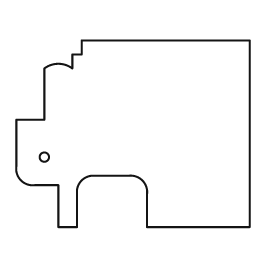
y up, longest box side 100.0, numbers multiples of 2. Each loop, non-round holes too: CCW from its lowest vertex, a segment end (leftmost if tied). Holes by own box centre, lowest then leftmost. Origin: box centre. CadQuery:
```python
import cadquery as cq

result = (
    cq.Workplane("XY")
    .moveTo(-32.0, -40.0)
    .lineTo(-24.0, -40.0)
    .lineTo(-24.0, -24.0)
    .threePointArc((-22.0, -20.0), (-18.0, -18.0))
    .lineTo(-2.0, -18.0)
    .threePointArc((4.0, -20.0), (6.0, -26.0))
    .lineTo(6.0, -40.0)
    .lineTo(50.0, -40.0)
    .lineTo(50.0, 40.0)
    .lineTo(-22.0, 40.0)
    .lineTo(-22.0, 34.0)
    .lineTo(-26.0, 34.0)
    .lineTo(-26.0, 28.0)
    .threePointArc((-32.0, 30.0), (-38.0, 28.0))
    .lineTo(-38.0, 6.0)
    .lineTo(-50.0, 6.0)
    .lineTo(-50.0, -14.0)
    .threePointArc((-48.0, -20.0), (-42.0, -22.0))
    .lineTo(-32.0, -22.0)
    .close()
    .moveTo(-38.0, -10.0)
    .circle(2.0)
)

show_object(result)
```